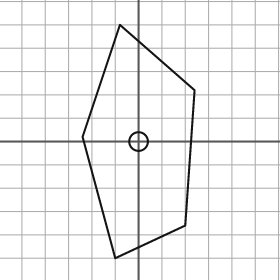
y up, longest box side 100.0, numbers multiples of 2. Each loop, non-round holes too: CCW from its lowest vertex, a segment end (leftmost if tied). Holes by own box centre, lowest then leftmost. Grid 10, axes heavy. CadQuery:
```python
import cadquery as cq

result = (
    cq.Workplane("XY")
    .moveTo(-10.0, -50.0)
    .lineTo(20.0, -36.0)
    .lineTo(24.0, 22.0)
    .lineTo(-8.0, 50.0)
    .lineTo(-24.0, 2.0)
    .close()
    .moveTo(0.0, 0.0)
    .circle(4.0)
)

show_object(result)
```